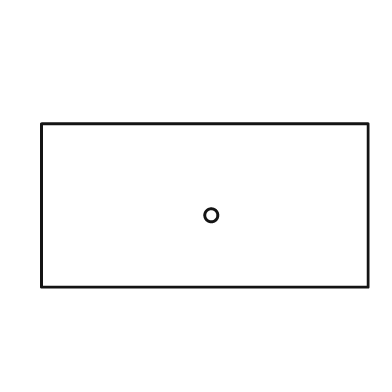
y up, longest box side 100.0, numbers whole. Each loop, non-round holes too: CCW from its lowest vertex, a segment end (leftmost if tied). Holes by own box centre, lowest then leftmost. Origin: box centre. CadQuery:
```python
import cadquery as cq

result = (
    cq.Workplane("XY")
    .moveTo(-50.0, -25.0)
    .lineTo(50.0, -25.0)
    .lineTo(50.0, 25.0)
    .lineTo(-50.0, 25.0)
    .close()
    .moveTo(2.0, -3.0)
    .circle(2.0)
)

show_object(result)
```